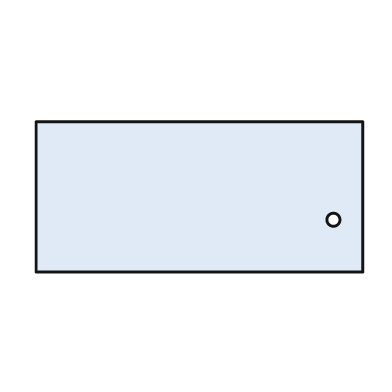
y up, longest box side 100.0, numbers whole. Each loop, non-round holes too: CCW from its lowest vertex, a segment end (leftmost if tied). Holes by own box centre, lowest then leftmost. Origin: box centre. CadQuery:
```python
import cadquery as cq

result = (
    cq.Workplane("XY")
    .moveTo(-50.0, -23.0)
    .lineTo(50.0, -23.0)
    .lineTo(50.0, 23.0)
    .lineTo(-50.0, 23.0)
    .close()
    .moveTo(41.0, -7.0)
    .circle(2.0)
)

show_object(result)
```